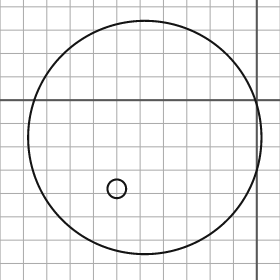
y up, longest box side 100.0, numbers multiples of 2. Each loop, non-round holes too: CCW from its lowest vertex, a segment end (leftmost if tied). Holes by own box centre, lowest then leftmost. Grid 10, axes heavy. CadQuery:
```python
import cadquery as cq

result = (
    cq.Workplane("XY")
    .moveTo(-48.0, -16.0)
    .circle(50.0)
    .moveTo(-60.0, -38.0)
    .circle(4.0)
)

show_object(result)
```